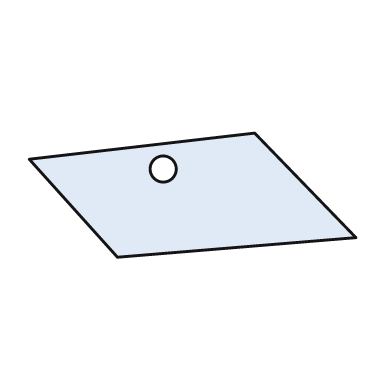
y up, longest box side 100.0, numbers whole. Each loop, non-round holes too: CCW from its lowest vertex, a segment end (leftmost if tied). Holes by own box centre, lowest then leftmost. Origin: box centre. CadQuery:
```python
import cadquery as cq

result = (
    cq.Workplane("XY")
    .moveTo(-23.0, -19.0)
    .lineTo(50.0, -13.0)
    .lineTo(19.0, 19.0)
    .lineTo(-50.0, 11.0)
    .close()
    .moveTo(-9.0, 8.0)
    .circle(4.0)
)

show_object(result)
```